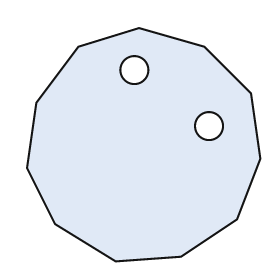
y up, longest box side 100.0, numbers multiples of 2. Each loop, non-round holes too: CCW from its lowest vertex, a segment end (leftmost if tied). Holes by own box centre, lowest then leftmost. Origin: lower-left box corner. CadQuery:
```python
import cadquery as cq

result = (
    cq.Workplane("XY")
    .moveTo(38.0, 0.0)
    .lineTo(66.0, 2.0)
    .lineTo(90.0, 18.0)
    .lineTo(100.0, 44.0)
    .lineTo(96.0, 72.0)
    .lineTo(76.0, 92.0)
    .lineTo(48.0, 100.0)
    .lineTo(22.0, 92.0)
    .lineTo(4.0, 68.0)
    .lineTo(0.0, 40.0)
    .lineTo(12.0, 16.0)
    .close()
    .moveTo(78.0, 58.0)
    .circle(6.0)
    .moveTo(46.0, 82.0)
    .circle(6.0)
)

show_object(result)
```